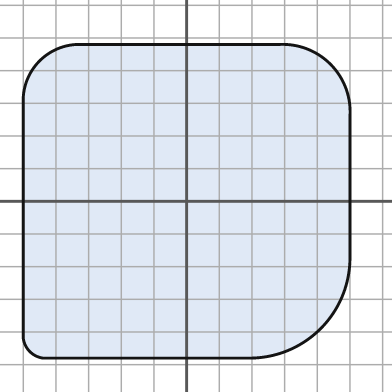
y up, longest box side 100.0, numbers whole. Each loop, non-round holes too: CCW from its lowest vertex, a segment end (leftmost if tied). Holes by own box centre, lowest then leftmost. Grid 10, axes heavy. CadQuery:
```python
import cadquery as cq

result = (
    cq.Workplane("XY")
    .moveTo(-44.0, -48.0)
    .lineTo(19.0, -48.0)
    .threePointArc((41.0, -39.0), (50.0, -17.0))
    .lineTo(50.0, 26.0)
    .threePointArc((44.0, 42.0), (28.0, 48.0))
    .lineTo(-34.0, 48.0)
    .threePointArc((-45.0, 43.0), (-50.0, 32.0))
    .lineTo(-50.0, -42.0)
    .threePointArc((-48.0, -46.0), (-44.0, -48.0))
    .close()
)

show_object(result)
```